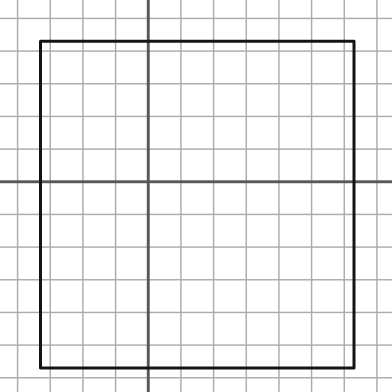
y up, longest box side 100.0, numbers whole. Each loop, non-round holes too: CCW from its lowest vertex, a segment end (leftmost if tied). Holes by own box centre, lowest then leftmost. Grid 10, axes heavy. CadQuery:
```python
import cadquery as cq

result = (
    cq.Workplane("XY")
    .moveTo(-33.0, -57.0)
    .lineTo(63.0, -57.0)
    .lineTo(63.0, 43.0)
    .lineTo(-33.0, 43.0)
    .close()
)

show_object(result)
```